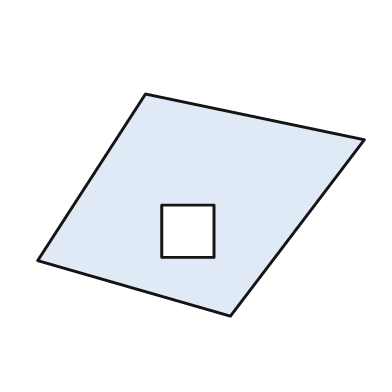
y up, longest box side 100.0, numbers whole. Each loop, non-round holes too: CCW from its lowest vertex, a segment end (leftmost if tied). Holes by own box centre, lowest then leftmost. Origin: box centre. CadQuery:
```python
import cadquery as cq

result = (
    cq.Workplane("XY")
    .moveTo(9.0, -34.0)
    .lineTo(50.0, 20.0)
    .lineTo(-17.0, 34.0)
    .lineTo(-50.0, -17.0)
    .close()
    .moveTo(-12.0, -16.0)
    .lineTo(4.0, -16.0)
    .lineTo(4.0, 0.0)
    .lineTo(-12.0, 0.0)
    .close()
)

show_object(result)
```